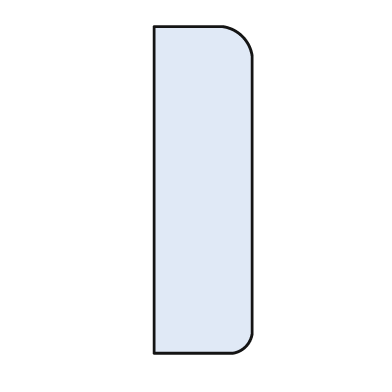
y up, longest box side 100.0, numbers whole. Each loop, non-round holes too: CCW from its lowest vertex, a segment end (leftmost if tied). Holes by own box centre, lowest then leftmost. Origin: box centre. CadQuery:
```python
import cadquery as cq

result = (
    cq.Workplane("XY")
    .moveTo(-15.0, -50.0)
    .lineTo(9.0, -50.0)
    .threePointArc((13.0, -48.0), (15.0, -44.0))
    .lineTo(15.0, 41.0)
    .threePointArc((12.0, 47.0), (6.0, 50.0))
    .lineTo(-15.0, 50.0)
    .close()
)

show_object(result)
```